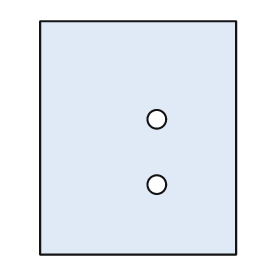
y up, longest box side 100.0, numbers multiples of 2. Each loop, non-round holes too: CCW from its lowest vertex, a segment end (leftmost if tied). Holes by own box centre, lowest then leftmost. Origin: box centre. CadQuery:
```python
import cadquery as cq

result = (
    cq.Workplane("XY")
    .moveTo(-42.0, -50.0)
    .lineTo(42.0, -50.0)
    .lineTo(42.0, 50.0)
    .lineTo(-42.0, 50.0)
    .close()
    .moveTo(8.0, -20.0)
    .circle(4.0)
    .moveTo(8.0, 8.0)
    .circle(4.0)
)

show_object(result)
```